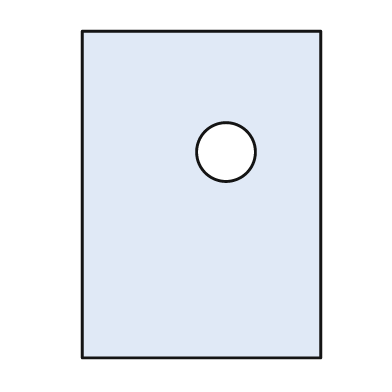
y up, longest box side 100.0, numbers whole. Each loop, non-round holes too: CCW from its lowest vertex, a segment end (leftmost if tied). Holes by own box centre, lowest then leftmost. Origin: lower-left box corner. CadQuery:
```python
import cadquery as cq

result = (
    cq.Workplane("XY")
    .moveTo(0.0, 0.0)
    .lineTo(73.0, 0.0)
    .lineTo(73.0, 100.0)
    .lineTo(0.0, 100.0)
    .close()
    .moveTo(44.0, 63.0)
    .circle(9.0)
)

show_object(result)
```